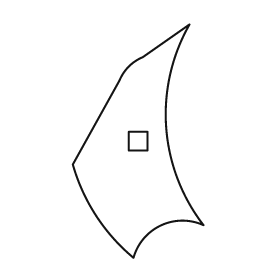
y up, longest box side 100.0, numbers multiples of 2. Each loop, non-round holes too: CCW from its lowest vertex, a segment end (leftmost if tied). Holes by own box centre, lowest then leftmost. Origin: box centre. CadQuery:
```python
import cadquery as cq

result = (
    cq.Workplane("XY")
    .moveTo(-2.0, -50.0)
    .threePointArc((10.0, -36.0), (28.0, -36.0))
    .threePointArc((12.0, 6.0), (22.0, 50.0))
    .lineTo(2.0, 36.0)
    .threePointArc((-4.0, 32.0), (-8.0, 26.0))
    .lineTo(-28.0, -10.0)
    .threePointArc((-18.0, -32.0), (-2.0, -50.0))
    .close()
    .moveTo(-4.0, -4.0)
    .lineTo(4.0, -4.0)
    .lineTo(4.0, 4.0)
    .lineTo(-4.0, 4.0)
    .close()
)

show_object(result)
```